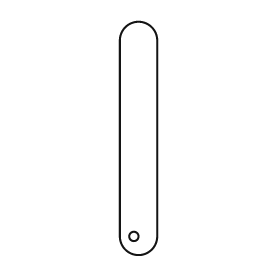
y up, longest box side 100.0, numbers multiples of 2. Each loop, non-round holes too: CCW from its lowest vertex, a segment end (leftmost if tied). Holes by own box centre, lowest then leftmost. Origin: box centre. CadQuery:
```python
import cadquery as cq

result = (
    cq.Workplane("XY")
    .moveTo(-8.0, -42.0)
    .threePointArc((0.0, -50.0), (8.0, -42.0))
    .lineTo(8.0, 42.0)
    .threePointArc((0.0, 50.0), (-8.0, 42.0))
    .close()
    .moveTo(-2.0, -42.0)
    .circle(2.0)
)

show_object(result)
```